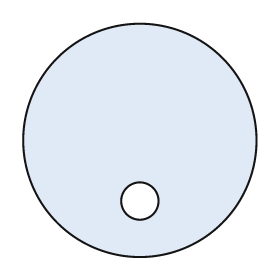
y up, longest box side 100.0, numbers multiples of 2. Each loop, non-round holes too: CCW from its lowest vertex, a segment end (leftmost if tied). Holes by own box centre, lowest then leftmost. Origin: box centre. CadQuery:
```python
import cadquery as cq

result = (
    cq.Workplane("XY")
    .moveTo(0.0, 0.0)
    .circle(50.0)
    .moveTo(0.0, -26.0)
    .circle(8.0)
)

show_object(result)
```